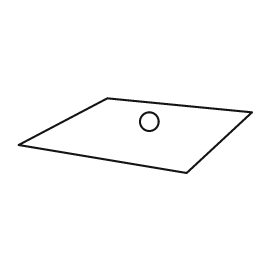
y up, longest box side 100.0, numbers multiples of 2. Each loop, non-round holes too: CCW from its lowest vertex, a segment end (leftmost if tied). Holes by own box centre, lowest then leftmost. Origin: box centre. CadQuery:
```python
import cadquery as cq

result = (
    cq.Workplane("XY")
    .moveTo(22.0, -16.0)
    .lineTo(50.0, 10.0)
    .lineTo(-12.0, 16.0)
    .lineTo(-50.0, -4.0)
    .close()
    .moveTo(6.0, 6.0)
    .circle(4.0)
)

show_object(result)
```